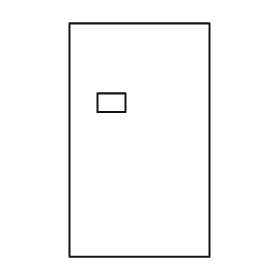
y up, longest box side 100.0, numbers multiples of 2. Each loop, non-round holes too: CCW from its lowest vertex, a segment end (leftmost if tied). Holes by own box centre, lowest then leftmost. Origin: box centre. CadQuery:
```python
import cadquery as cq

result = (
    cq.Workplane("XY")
    .moveTo(-30.0, -50.0)
    .lineTo(30.0, -50.0)
    .lineTo(30.0, 50.0)
    .lineTo(-30.0, 50.0)
    .close()
    .moveTo(-18.0, 12.0)
    .lineTo(-6.0, 12.0)
    .lineTo(-6.0, 20.0)
    .lineTo(-18.0, 20.0)
    .close()
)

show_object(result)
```